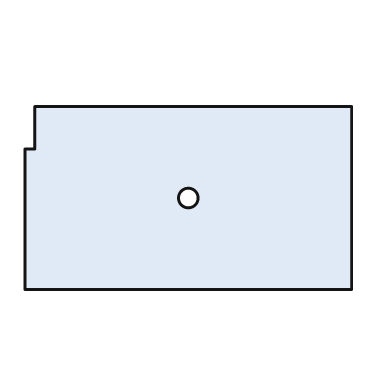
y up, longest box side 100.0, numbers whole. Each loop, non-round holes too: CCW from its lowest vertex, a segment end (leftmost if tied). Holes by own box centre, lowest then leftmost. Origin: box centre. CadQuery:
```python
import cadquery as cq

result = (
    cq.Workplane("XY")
    .moveTo(-50.0, -28.0)
    .lineTo(50.0, -28.0)
    .lineTo(50.0, 28.0)
    .lineTo(-47.0, 28.0)
    .lineTo(-47.0, 15.0)
    .lineTo(-50.0, 15.0)
    .close()
    .moveTo(0.0, 0.0)
    .circle(3.0)
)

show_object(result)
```